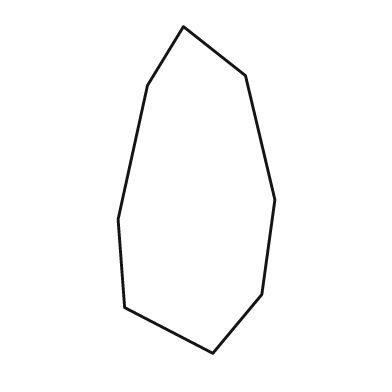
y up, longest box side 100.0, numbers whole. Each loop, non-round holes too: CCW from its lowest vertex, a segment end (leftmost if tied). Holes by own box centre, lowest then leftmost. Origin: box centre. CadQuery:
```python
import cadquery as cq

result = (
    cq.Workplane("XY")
    .moveTo(5.0, -50.0)
    .lineTo(20.0, -32.0)
    .lineTo(24.0, -3.0)
    .lineTo(15.0, 35.0)
    .lineTo(-4.0, 50.0)
    .lineTo(-15.0, 32.0)
    .lineTo(-24.0, -9.0)
    .lineTo(-22.0, -36.0)
    .close()
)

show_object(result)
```